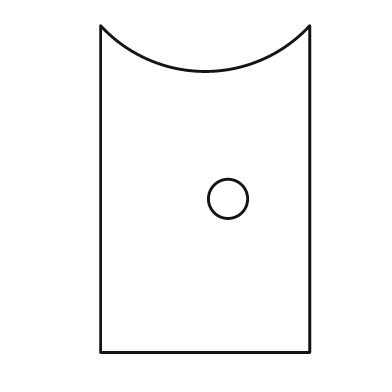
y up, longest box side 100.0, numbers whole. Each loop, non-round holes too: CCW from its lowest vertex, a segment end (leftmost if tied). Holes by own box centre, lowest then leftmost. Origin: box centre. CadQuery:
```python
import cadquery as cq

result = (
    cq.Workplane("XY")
    .moveTo(-32.0, -50.0)
    .lineTo(32.0, -50.0)
    .lineTo(32.0, 50.0)
    .threePointArc((0.0, 36.0), (-32.0, 50.0))
    .close()
    .moveTo(7.0, -3.0)
    .circle(6.0)
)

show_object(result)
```